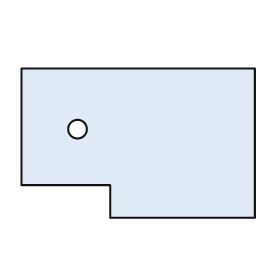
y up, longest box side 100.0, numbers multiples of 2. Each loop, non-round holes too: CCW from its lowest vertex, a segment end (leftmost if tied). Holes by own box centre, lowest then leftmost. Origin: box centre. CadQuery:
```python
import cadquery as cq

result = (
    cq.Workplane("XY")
    .moveTo(-12.0, -32.0)
    .lineTo(50.0, -32.0)
    .lineTo(50.0, 32.0)
    .lineTo(-50.0, 32.0)
    .lineTo(-50.0, -18.0)
    .lineTo(-12.0, -18.0)
    .close()
    .moveTo(-26.0, 6.0)
    .circle(4.0)
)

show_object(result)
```